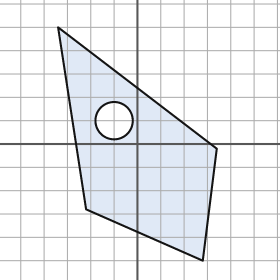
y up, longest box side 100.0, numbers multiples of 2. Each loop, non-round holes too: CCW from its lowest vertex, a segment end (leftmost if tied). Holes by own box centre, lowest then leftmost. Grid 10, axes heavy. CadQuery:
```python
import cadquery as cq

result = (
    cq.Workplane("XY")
    .moveTo(28.0, -50.0)
    .lineTo(34.0, -2.0)
    .lineTo(-34.0, 50.0)
    .lineTo(-22.0, -28.0)
    .close()
    .moveTo(-10.0, 10.0)
    .circle(8.0)
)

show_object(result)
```